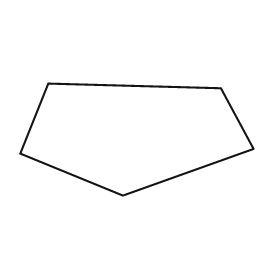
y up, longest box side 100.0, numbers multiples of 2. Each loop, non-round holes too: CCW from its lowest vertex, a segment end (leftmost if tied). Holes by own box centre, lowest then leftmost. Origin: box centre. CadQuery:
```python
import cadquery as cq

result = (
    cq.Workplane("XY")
    .moveTo(-6.0, -24.0)
    .lineTo(50.0, -4.0)
    .lineTo(36.0, 22.0)
    .lineTo(-38.0, 24.0)
    .lineTo(-50.0, -6.0)
    .close()
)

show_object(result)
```